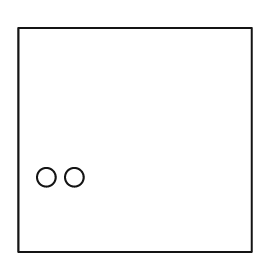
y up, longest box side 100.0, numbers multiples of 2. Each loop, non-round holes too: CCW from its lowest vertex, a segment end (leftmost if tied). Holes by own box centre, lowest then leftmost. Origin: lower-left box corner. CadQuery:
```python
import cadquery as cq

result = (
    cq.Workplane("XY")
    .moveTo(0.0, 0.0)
    .lineTo(100.0, 0.0)
    .lineTo(100.0, 96.0)
    .lineTo(0.0, 96.0)
    .close()
    .moveTo(12.0, 32.0)
    .circle(4.0)
    .moveTo(24.0, 32.0)
    .circle(4.0)
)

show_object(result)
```